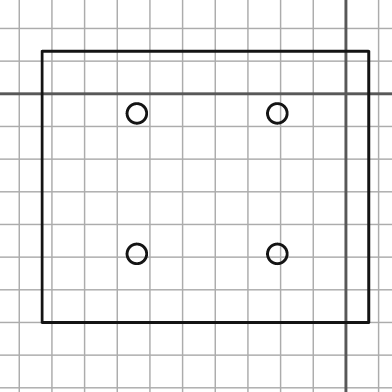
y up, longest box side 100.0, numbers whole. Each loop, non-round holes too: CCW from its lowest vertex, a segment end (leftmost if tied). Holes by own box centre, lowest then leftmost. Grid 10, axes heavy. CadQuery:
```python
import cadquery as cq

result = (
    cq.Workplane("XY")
    .moveTo(-93.0, -70.0)
    .lineTo(7.0, -70.0)
    .lineTo(7.0, 13.0)
    .lineTo(-93.0, 13.0)
    .close()
    .moveTo(-64.0, -49.0)
    .circle(3.0)
    .moveTo(-21.0, -49.0)
    .circle(3.0)
    .moveTo(-64.0, -6.0)
    .circle(3.0)
    .moveTo(-21.0, -6.0)
    .circle(3.0)
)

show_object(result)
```